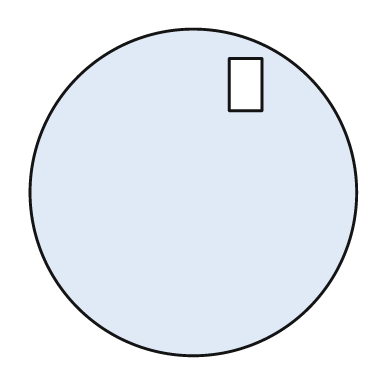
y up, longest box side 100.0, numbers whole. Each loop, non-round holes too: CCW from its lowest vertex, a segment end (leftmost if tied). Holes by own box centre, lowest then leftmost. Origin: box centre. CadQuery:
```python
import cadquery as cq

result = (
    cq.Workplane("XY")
    .moveTo(0.0, 0.0)
    .circle(50.0)
    .moveTo(11.0, 25.0)
    .lineTo(21.0, 25.0)
    .lineTo(21.0, 41.0)
    .lineTo(11.0, 41.0)
    .close()
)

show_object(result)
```